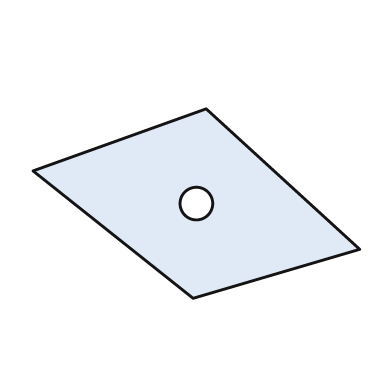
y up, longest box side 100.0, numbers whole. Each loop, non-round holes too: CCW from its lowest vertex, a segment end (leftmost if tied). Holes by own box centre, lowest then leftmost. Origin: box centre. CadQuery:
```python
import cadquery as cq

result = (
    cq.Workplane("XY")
    .moveTo(-1.0, -29.0)
    .lineTo(50.0, -14.0)
    .lineTo(3.0, 29.0)
    .lineTo(-50.0, 10.0)
    .close()
    .moveTo(0.0, 0.0)
    .circle(5.0)
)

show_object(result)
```